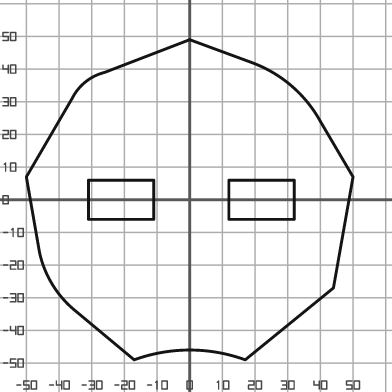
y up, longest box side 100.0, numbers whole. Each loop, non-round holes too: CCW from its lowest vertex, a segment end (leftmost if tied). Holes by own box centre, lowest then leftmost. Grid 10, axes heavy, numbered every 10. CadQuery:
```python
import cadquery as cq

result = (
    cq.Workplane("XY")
    .moveTo(-17.0, -49.0)
    .threePointArc((0.0, -46.0), (17.0, -49.0))
    .lineTo(44.0, -27.0)
    .lineTo(50.0, 7.0)
    .lineTo(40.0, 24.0)
    .threePointArc((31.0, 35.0), (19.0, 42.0))
    .lineTo(0.0, 49.0)
    .lineTo(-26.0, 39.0)
    .threePointArc((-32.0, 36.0), (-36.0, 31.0))
    .lineTo(-50.0, 7.0)
    .lineTo(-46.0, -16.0)
    .threePointArc((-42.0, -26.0), (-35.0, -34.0))
    .close()
    .moveTo(-31.0, -6.0)
    .lineTo(-11.0, -6.0)
    .lineTo(-11.0, 6.0)
    .lineTo(-31.0, 6.0)
    .close()
    .moveTo(12.0, -6.0)
    .lineTo(32.0, -6.0)
    .lineTo(32.0, 6.0)
    .lineTo(12.0, 6.0)
    .close()
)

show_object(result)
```